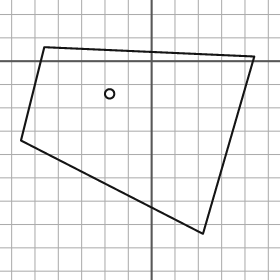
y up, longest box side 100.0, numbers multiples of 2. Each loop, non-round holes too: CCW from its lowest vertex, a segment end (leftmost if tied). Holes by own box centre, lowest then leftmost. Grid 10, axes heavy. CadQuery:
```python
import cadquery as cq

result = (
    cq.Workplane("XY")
    .moveTo(22.0, -74.0)
    .lineTo(44.0, 2.0)
    .lineTo(-46.0, 6.0)
    .lineTo(-56.0, -34.0)
    .close()
    .moveTo(-18.0, -14.0)
    .circle(2.0)
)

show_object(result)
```